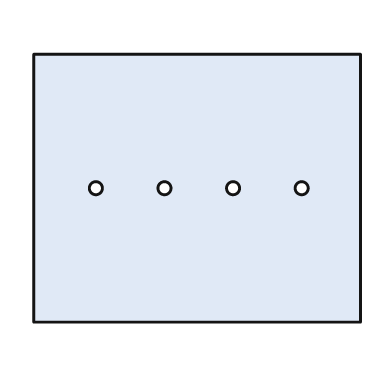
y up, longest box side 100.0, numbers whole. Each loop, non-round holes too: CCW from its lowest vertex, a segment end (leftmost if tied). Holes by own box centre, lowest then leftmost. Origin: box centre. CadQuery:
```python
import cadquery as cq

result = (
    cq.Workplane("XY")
    .moveTo(-50.0, -41.0)
    .lineTo(50.0, -41.0)
    .lineTo(50.0, 41.0)
    .lineTo(-50.0, 41.0)
    .close()
    .moveTo(-31.0, 0.0)
    .circle(2.0)
    .moveTo(-10.0, 0.0)
    .circle(2.0)
    .moveTo(11.0, 0.0)
    .circle(2.0)
    .moveTo(32.0, 0.0)
    .circle(2.0)
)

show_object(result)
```